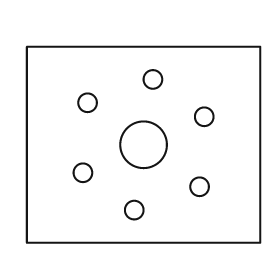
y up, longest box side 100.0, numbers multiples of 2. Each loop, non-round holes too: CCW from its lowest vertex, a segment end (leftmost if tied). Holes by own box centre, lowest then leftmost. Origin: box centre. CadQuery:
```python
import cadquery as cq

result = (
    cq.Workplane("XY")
    .moveTo(-50.0, -42.0)
    .lineTo(50.0, -42.0)
    .lineTo(50.0, 42.0)
    .lineTo(-50.0, 42.0)
    .close()
    .moveTo(-4.0, -28.0)
    .circle(4.0)
    .moveTo(24.0, -18.0)
    .circle(4.0)
    .moveTo(-26.0, -12.0)
    .circle(4.0)
    .moveTo(0.0, 0.0)
    .circle(10.0)
    .moveTo(26.0, 12.0)
    .circle(4.0)
    .moveTo(-24.0, 18.0)
    .circle(4.0)
    .moveTo(4.0, 28.0)
    .circle(4.0)
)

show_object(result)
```